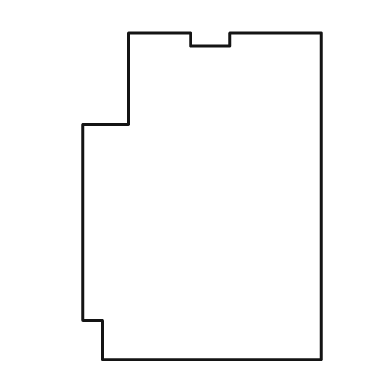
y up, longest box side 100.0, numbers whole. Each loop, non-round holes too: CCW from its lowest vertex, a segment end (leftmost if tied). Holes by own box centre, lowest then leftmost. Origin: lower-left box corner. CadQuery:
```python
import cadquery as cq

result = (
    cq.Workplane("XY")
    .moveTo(6.0, 0.0)
    .lineTo(73.0, 0.0)
    .lineTo(73.0, 100.0)
    .lineTo(45.0, 100.0)
    .lineTo(45.0, 96.0)
    .lineTo(33.0, 96.0)
    .lineTo(33.0, 100.0)
    .lineTo(14.0, 100.0)
    .lineTo(14.0, 72.0)
    .lineTo(0.0, 72.0)
    .lineTo(0.0, 12.0)
    .lineTo(6.0, 12.0)
    .close()
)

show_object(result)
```